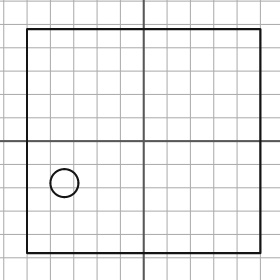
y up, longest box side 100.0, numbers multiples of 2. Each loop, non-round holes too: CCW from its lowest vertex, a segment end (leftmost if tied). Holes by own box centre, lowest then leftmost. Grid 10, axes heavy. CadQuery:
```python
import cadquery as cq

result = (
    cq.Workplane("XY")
    .moveTo(-50.0, -48.0)
    .lineTo(50.0, -48.0)
    .lineTo(50.0, 48.0)
    .lineTo(-50.0, 48.0)
    .close()
    .moveTo(-34.0, -18.0)
    .circle(6.0)
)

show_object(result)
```